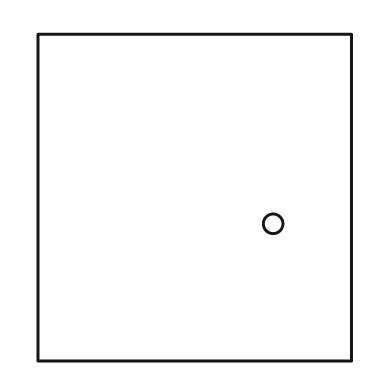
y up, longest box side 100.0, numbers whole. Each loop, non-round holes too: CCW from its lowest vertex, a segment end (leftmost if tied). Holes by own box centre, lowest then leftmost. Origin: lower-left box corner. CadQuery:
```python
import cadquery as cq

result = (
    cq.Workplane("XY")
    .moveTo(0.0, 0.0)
    .lineTo(96.0, 0.0)
    .lineTo(96.0, 100.0)
    .lineTo(0.0, 100.0)
    .close()
    .moveTo(72.0, 42.0)
    .circle(3.0)
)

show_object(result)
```